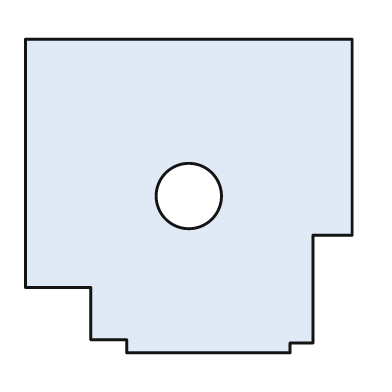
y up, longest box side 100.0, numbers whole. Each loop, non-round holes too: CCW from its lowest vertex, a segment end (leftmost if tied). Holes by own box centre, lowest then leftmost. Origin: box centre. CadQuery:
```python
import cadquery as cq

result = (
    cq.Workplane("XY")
    .moveTo(-19.0, -48.0)
    .lineTo(31.0, -48.0)
    .lineTo(31.0, -45.0)
    .lineTo(38.0, -45.0)
    .lineTo(38.0, -12.0)
    .lineTo(50.0, -12.0)
    .lineTo(50.0, 48.0)
    .lineTo(-50.0, 48.0)
    .lineTo(-50.0, -28.0)
    .lineTo(-30.0, -28.0)
    .lineTo(-30.0, -44.0)
    .lineTo(-19.0, -44.0)
    .close()
    .moveTo(0.0, 0.0)
    .circle(10.0)
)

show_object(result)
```